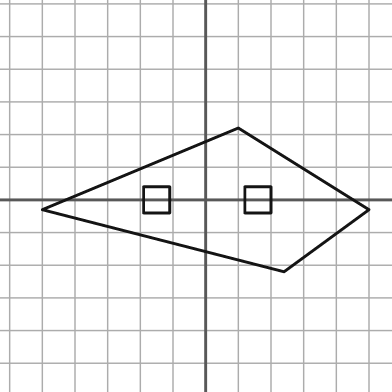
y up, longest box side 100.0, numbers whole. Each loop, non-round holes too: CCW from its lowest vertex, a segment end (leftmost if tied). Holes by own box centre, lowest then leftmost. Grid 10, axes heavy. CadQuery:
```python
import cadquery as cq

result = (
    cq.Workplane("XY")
    .moveTo(24.0, -22.0)
    .lineTo(50.0, -3.0)
    .lineTo(10.0, 22.0)
    .lineTo(-50.0, -3.0)
    .close()
    .moveTo(-19.0, -4.0)
    .lineTo(-11.0, -4.0)
    .lineTo(-11.0, 4.0)
    .lineTo(-19.0, 4.0)
    .close()
    .moveTo(12.0, -4.0)
    .lineTo(20.0, -4.0)
    .lineTo(20.0, 4.0)
    .lineTo(12.0, 4.0)
    .close()
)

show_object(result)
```